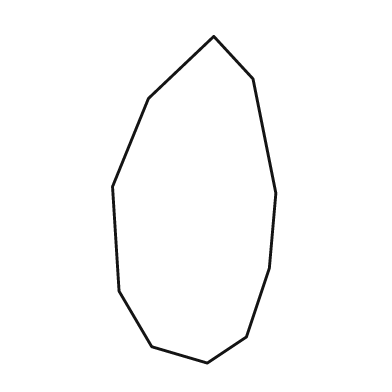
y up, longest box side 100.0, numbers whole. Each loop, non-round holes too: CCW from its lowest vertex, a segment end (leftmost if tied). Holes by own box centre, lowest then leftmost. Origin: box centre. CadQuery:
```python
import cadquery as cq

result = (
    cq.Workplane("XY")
    .moveTo(4.0, -50.0)
    .lineTo(16.0, -42.0)
    .lineTo(23.0, -21.0)
    .lineTo(25.0, 2.0)
    .lineTo(18.0, 37.0)
    .lineTo(6.0, 50.0)
    .lineTo(-14.0, 31.0)
    .lineTo(-25.0, 4.0)
    .lineTo(-23.0, -28.0)
    .lineTo(-13.0, -45.0)
    .close()
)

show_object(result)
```